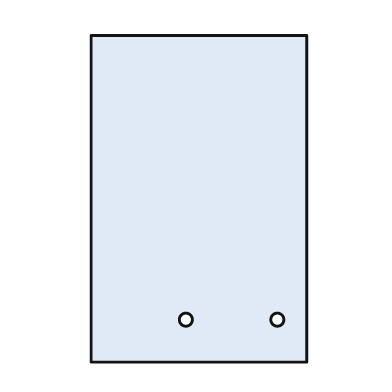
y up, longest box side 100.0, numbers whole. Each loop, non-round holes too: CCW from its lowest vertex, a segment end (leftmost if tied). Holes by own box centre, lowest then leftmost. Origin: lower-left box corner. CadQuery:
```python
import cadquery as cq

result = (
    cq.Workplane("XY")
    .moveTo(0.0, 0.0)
    .lineTo(66.0, 0.0)
    .lineTo(66.0, 100.0)
    .lineTo(0.0, 100.0)
    .close()
    .moveTo(29.0, 13.0)
    .circle(2.0)
    .moveTo(57.0, 13.0)
    .circle(2.0)
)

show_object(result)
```